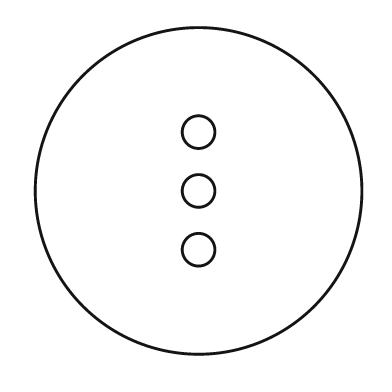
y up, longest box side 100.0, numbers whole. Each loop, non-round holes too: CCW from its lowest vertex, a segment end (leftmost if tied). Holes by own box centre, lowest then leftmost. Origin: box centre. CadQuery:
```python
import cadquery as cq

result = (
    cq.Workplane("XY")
    .moveTo(0.0, 0.0)
    .circle(50.0)
    .moveTo(0.0, -18.0)
    .circle(5.0)
    .moveTo(0.0, 0.0)
    .circle(5.0)
    .moveTo(0.0, 18.0)
    .circle(5.0)
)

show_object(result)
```